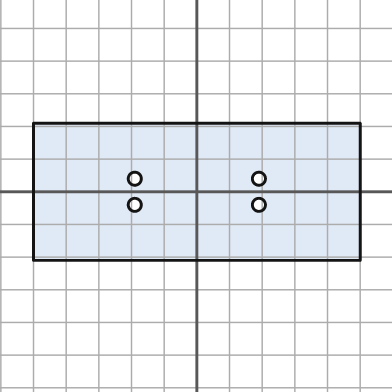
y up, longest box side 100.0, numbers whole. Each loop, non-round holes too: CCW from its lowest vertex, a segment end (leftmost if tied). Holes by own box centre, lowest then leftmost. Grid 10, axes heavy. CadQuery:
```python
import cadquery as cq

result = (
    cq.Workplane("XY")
    .moveTo(-50.0, -21.0)
    .lineTo(50.0, -21.0)
    .lineTo(50.0, 21.0)
    .lineTo(-50.0, 21.0)
    .close()
    .moveTo(-19.0, -4.0)
    .circle(2.0)
    .moveTo(19.0, -4.0)
    .circle(2.0)
    .moveTo(-19.0, 4.0)
    .circle(2.0)
    .moveTo(19.0, 4.0)
    .circle(2.0)
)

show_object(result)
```